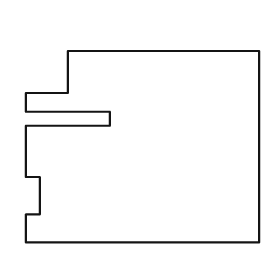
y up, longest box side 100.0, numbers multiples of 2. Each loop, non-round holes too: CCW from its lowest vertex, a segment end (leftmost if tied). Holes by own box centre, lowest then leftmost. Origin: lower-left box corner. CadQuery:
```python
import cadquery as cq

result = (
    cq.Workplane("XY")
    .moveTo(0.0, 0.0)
    .lineTo(100.0, 0.0)
    .lineTo(100.0, 82.0)
    .lineTo(18.0, 82.0)
    .lineTo(18.0, 64.0)
    .lineTo(0.0, 64.0)
    .lineTo(0.0, 56.0)
    .lineTo(36.0, 56.0)
    .lineTo(36.0, 50.0)
    .lineTo(0.0, 50.0)
    .lineTo(0.0, 28.0)
    .lineTo(6.0, 28.0)
    .lineTo(6.0, 12.0)
    .lineTo(0.0, 12.0)
    .close()
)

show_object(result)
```